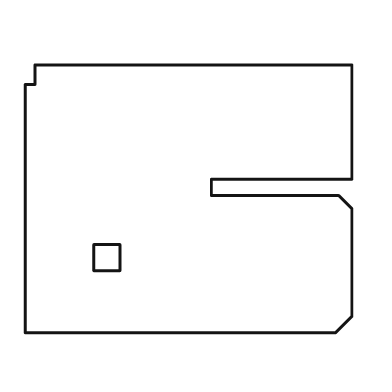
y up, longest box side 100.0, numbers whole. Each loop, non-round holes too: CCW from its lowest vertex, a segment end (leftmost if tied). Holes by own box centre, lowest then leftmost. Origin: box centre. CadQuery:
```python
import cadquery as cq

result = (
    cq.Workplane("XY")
    .moveTo(-50.0, -41.0)
    .lineTo(45.0, -41.0)
    .lineTo(50.0, -36.0)
    .lineTo(50.0, -3.0)
    .lineTo(46.0, 1.0)
    .lineTo(7.0, 1.0)
    .lineTo(7.0, 6.0)
    .lineTo(50.0, 6.0)
    .lineTo(50.0, 41.0)
    .lineTo(-47.0, 41.0)
    .lineTo(-47.0, 35.0)
    .lineTo(-50.0, 35.0)
    .close()
    .moveTo(-29.0, -22.0)
    .lineTo(-21.0, -22.0)
    .lineTo(-21.0, -14.0)
    .lineTo(-29.0, -14.0)
    .close()
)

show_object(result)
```